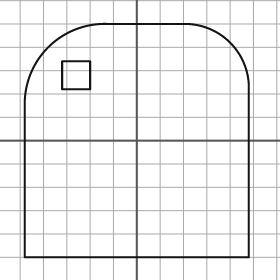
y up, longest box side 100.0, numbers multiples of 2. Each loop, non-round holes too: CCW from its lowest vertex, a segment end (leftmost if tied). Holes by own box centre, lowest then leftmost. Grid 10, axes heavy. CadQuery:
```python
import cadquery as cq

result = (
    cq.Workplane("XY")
    .moveTo(-48.0, -50.0)
    .lineTo(48.0, -50.0)
    .lineTo(48.0, 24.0)
    .threePointArc((40.0, 42.0), (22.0, 50.0))
    .lineTo(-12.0, 50.0)
    .threePointArc((-38.0, 40.0), (-48.0, 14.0))
    .close()
    .moveTo(-32.0, 22.0)
    .lineTo(-20.0, 22.0)
    .lineTo(-20.0, 34.0)
    .lineTo(-32.0, 34.0)
    .close()
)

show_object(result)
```